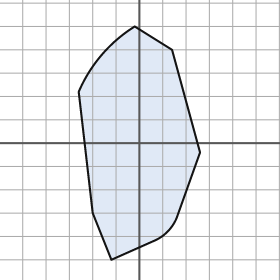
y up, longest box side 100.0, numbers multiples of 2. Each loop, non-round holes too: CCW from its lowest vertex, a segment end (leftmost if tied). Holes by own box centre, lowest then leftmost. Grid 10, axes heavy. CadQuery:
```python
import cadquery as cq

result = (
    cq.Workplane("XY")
    .moveTo(-12.0, -50.0)
    .lineTo(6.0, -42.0)
    .threePointArc((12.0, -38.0), (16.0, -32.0))
    .lineTo(26.0, -4.0)
    .lineTo(14.0, 40.0)
    .lineTo(-2.0, 50.0)
    .threePointArc((-16.0, 38.0), (-26.0, 22.0))
    .lineTo(-20.0, -30.0)
    .close()
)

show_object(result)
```